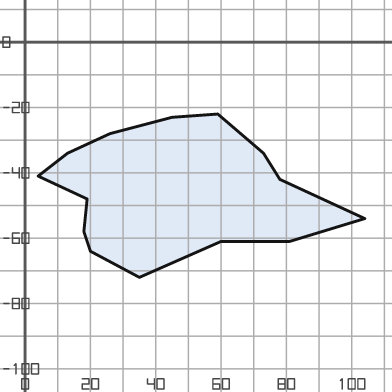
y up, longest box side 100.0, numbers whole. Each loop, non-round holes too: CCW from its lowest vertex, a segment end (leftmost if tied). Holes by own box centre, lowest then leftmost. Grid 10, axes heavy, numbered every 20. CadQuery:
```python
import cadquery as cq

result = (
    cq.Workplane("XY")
    .moveTo(35.0, -72.0)
    .lineTo(60.0, -61.0)
    .lineTo(81.0, -61.0)
    .lineTo(104.0, -54.0)
    .lineTo(78.0, -42.0)
    .lineTo(73.0, -34.0)
    .lineTo(59.0, -22.0)
    .lineTo(45.0, -23.0)
    .lineTo(26.0, -28.0)
    .lineTo(13.0, -34.0)
    .lineTo(4.0, -41.0)
    .lineTo(19.0, -48.0)
    .lineTo(18.0, -58.0)
    .lineTo(20.0, -64.0)
    .close()
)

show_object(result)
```